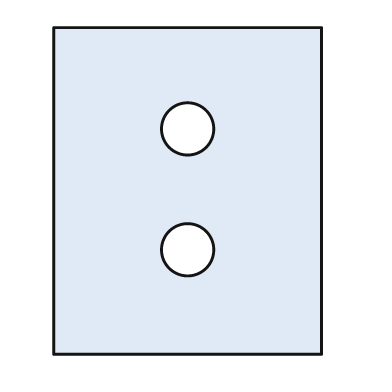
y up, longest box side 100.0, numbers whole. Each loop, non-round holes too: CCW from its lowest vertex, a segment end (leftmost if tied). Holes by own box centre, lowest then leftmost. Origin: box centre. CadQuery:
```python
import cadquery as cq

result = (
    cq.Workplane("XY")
    .moveTo(-41.0, -50.0)
    .lineTo(41.0, -50.0)
    .lineTo(41.0, 50.0)
    .lineTo(-41.0, 50.0)
    .close()
    .moveTo(0.0, -18.0)
    .circle(8.0)
    .moveTo(0.0, 19.0)
    .circle(8.0)
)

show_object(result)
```